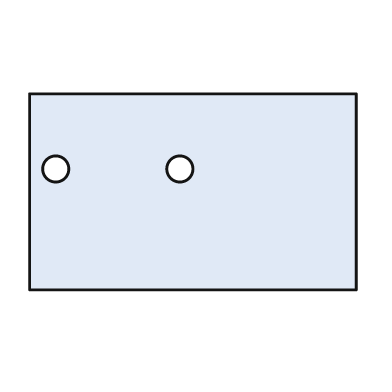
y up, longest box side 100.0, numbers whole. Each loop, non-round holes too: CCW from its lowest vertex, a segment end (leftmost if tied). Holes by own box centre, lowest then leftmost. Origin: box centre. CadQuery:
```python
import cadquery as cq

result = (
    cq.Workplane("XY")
    .moveTo(-50.0, -30.0)
    .lineTo(50.0, -30.0)
    .lineTo(50.0, 30.0)
    .lineTo(-50.0, 30.0)
    .close()
    .moveTo(-42.0, 7.0)
    .circle(4.0)
    .moveTo(-4.0, 7.0)
    .circle(4.0)
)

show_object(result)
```